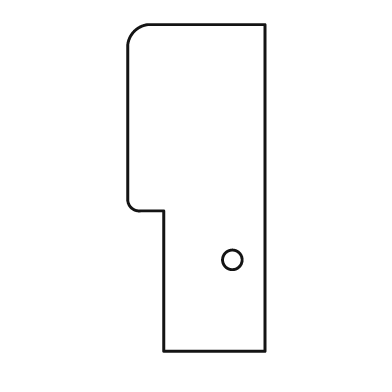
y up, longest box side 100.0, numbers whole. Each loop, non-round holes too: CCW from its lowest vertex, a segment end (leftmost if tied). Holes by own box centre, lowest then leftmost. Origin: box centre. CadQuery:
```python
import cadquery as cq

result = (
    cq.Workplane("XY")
    .moveTo(-10.0, -50.0)
    .lineTo(21.0, -50.0)
    .lineTo(21.0, 50.0)
    .lineTo(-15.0, 50.0)
    .threePointArc((-19.0, 48.0), (-21.0, 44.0))
    .lineTo(-21.0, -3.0)
    .threePointArc((-20.0, -6.0), (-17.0, -7.0))
    .lineTo(-10.0, -7.0)
    .close()
    .moveTo(11.0, -22.0)
    .circle(3.0)
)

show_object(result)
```